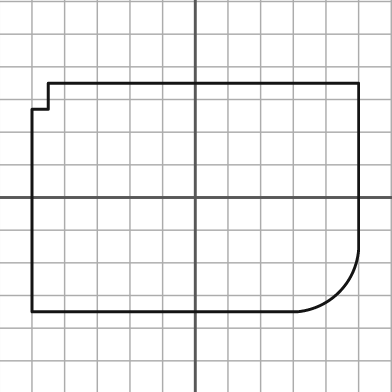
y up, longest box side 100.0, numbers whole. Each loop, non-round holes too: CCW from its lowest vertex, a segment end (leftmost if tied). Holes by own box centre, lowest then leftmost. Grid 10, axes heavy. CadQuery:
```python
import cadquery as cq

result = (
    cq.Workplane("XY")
    .moveTo(-50.0, -35.0)
    .lineTo(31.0, -35.0)
    .threePointArc((44.0, -29.0), (50.0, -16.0))
    .lineTo(50.0, 35.0)
    .lineTo(-45.0, 35.0)
    .lineTo(-45.0, 27.0)
    .lineTo(-50.0, 27.0)
    .close()
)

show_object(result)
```